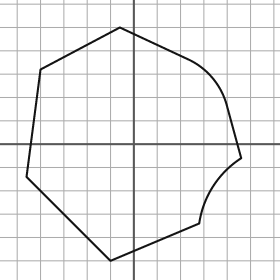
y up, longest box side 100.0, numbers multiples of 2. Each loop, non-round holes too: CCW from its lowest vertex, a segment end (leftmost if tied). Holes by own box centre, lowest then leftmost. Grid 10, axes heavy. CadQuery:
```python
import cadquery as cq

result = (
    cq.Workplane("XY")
    .moveTo(-10.0, -50.0)
    .lineTo(28.0, -34.0)
    .threePointArc((34.0, -18.0), (46.0, -6.0))
    .lineTo(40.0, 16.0)
    .threePointArc((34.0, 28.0), (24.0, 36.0))
    .lineTo(-6.0, 50.0)
    .lineTo(-40.0, 32.0)
    .lineTo(-46.0, -14.0)
    .close()
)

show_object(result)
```